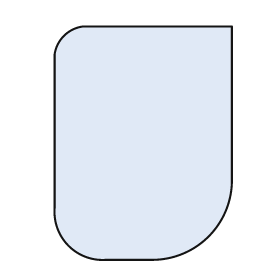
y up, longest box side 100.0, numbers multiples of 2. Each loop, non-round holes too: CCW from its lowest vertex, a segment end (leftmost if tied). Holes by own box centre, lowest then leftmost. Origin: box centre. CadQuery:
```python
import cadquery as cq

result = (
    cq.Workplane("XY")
    .moveTo(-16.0, -50.0)
    .lineTo(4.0, -50.0)
    .threePointArc((28.0, -40.0), (38.0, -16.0))
    .lineTo(38.0, 50.0)
    .lineTo(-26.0, 50.0)
    .threePointArc((-34.0, 46.0), (-38.0, 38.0))
    .lineTo(-38.0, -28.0)
    .threePointArc((-32.0, -44.0), (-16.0, -50.0))
    .close()
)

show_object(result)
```